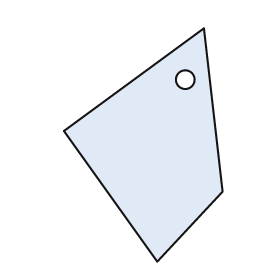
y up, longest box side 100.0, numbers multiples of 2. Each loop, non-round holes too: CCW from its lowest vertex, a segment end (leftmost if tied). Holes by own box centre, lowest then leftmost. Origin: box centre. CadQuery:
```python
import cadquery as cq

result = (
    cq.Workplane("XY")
    .moveTo(6.0, -50.0)
    .lineTo(34.0, -20.0)
    .lineTo(26.0, 50.0)
    .lineTo(-34.0, 6.0)
    .close()
    .moveTo(18.0, 28.0)
    .circle(4.0)
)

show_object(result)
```